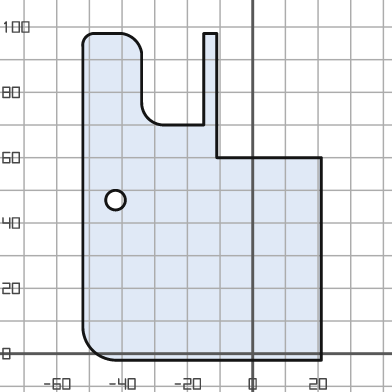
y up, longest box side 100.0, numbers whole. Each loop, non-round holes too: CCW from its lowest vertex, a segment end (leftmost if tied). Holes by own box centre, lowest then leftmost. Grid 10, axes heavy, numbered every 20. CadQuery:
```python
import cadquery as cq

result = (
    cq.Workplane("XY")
    .moveTo(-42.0, -2.0)
    .lineTo(21.0, -2.0)
    .lineTo(21.0, 60.0)
    .lineTo(-11.0, 60.0)
    .lineTo(-11.0, 98.0)
    .lineTo(-15.0, 98.0)
    .lineTo(-15.0, 70.0)
    .lineTo(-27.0, 70.0)
    .threePointArc((-32.0, 72.0), (-34.0, 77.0))
    .lineTo(-34.0, 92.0)
    .threePointArc((-36.0, 96.0), (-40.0, 98.0))
    .lineTo(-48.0, 98.0)
    .threePointArc((-51.0, 97.0), (-52.0, 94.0))
    .lineTo(-52.0, 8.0)
    .threePointArc((-49.0, 1.0), (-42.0, -2.0))
    .close()
    .moveTo(-42.0, 47.0)
    .circle(3.0)
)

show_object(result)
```